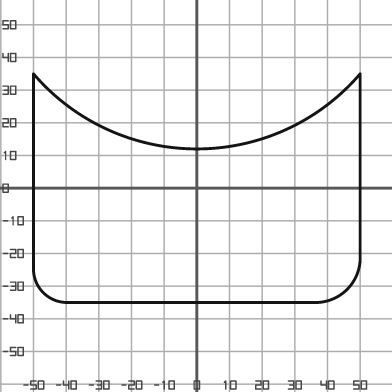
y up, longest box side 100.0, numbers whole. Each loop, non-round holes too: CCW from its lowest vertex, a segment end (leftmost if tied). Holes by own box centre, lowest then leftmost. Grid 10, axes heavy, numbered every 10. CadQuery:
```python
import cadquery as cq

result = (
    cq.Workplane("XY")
    .moveTo(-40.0, -35.0)
    .lineTo(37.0, -35.0)
    .threePointArc((46.0, -31.0), (50.0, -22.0))
    .lineTo(50.0, 35.0)
    .threePointArc((0.0, 12.0), (-50.0, 35.0))
    .lineTo(-50.0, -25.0)
    .threePointArc((-47.0, -32.0), (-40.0, -35.0))
    .close()
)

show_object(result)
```